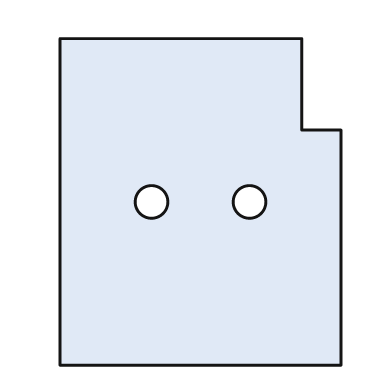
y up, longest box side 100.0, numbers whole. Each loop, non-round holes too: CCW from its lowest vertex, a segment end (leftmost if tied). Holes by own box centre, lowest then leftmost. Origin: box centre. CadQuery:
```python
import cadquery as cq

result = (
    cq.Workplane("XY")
    .moveTo(-43.0, -50.0)
    .lineTo(43.0, -50.0)
    .lineTo(43.0, 22.0)
    .lineTo(31.0, 22.0)
    .lineTo(31.0, 50.0)
    .lineTo(-43.0, 50.0)
    .close()
    .moveTo(-15.0, 0.0)
    .circle(5.0)
    .moveTo(15.0, 0.0)
    .circle(5.0)
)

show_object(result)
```